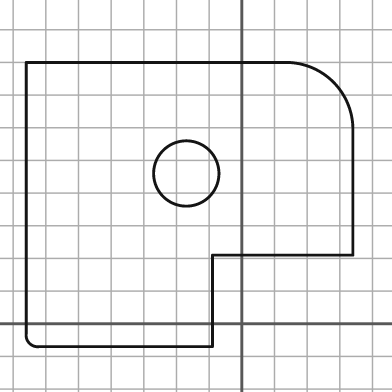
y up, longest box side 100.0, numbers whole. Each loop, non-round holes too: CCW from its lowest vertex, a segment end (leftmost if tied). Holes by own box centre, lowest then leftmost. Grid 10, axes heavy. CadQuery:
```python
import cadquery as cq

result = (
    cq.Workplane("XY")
    .moveTo(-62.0, -7.0)
    .lineTo(-9.0, -7.0)
    .lineTo(-9.0, 21.0)
    .lineTo(34.0, 21.0)
    .lineTo(34.0, 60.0)
    .threePointArc((28.0, 74.0), (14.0, 80.0))
    .lineTo(-66.0, 80.0)
    .lineTo(-66.0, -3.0)
    .threePointArc((-65.0, -6.0), (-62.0, -7.0))
    .close()
    .moveTo(-17.0, 46.0)
    .circle(10.0)
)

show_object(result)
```